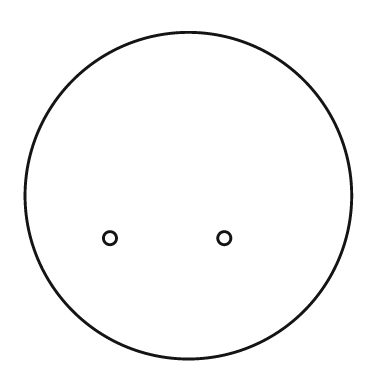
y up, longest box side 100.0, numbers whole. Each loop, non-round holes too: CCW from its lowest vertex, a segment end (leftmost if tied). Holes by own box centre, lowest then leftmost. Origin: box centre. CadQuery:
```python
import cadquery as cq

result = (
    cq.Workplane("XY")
    .moveTo(0.0, 0.0)
    .circle(50.0)
    .moveTo(-24.0, -13.0)
    .circle(2.0)
    .moveTo(11.0, -13.0)
    .circle(2.0)
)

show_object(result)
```